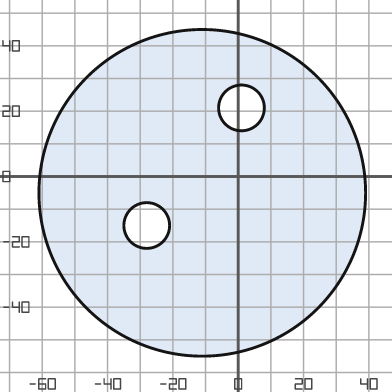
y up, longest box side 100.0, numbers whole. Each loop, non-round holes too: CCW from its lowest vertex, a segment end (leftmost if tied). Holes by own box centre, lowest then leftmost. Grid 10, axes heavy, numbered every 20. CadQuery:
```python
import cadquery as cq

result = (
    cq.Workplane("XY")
    .moveTo(-11.0, -5.0)
    .circle(50.0)
    .moveTo(-28.0, -15.0)
    .circle(7.0)
    .moveTo(1.0, 21.0)
    .circle(7.0)
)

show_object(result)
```